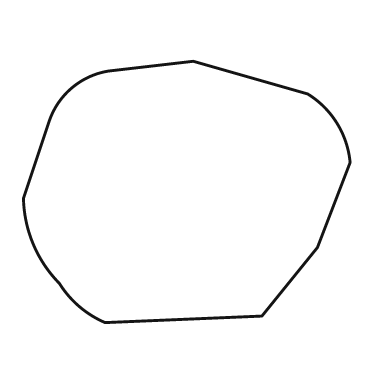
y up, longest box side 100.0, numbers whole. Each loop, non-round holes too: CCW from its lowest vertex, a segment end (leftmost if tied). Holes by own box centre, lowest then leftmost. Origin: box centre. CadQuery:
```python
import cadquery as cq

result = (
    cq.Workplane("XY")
    .moveTo(-25.0, -40.0)
    .lineTo(23.0, -38.0)
    .lineTo(40.0, -17.0)
    .lineTo(50.0, 9.0)
    .threePointArc((46.0, 21.0), (37.0, 30.0))
    .lineTo(2.0, 40.0)
    .lineTo(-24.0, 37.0)
    .threePointArc((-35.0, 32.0), (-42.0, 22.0))
    .lineTo(-50.0, -2.0)
    .threePointArc((-47.0, -16.0), (-39.0, -28.0))
    .threePointArc((-33.0, -35.0), (-25.0, -40.0))
    .close()
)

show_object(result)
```